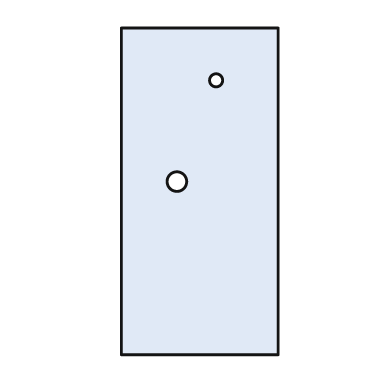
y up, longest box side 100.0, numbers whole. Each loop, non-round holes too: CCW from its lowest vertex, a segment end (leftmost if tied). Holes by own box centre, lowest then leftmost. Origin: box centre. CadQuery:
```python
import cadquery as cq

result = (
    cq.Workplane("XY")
    .moveTo(-24.0, -50.0)
    .lineTo(24.0, -50.0)
    .lineTo(24.0, 50.0)
    .lineTo(-24.0, 50.0)
    .close()
    .moveTo(-7.0, 3.0)
    .circle(3.0)
    .moveTo(5.0, 34.0)
    .circle(2.0)
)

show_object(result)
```